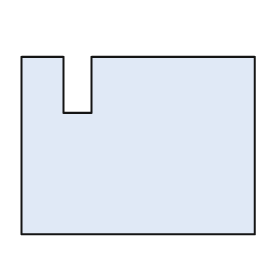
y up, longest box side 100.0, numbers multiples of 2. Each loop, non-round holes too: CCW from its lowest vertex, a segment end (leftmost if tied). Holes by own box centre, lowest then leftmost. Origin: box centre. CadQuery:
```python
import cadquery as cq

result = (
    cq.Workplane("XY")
    .moveTo(-50.0, -38.0)
    .lineTo(50.0, -38.0)
    .lineTo(50.0, 38.0)
    .lineTo(-20.0, 38.0)
    .lineTo(-20.0, 14.0)
    .lineTo(-32.0, 14.0)
    .lineTo(-32.0, 38.0)
    .lineTo(-50.0, 38.0)
    .close()
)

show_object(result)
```